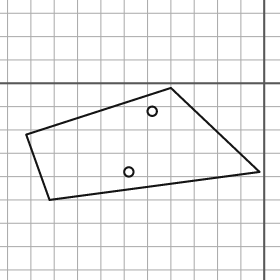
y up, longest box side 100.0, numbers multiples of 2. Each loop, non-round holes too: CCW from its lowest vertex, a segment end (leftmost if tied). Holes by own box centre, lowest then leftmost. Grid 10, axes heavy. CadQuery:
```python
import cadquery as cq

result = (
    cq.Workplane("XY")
    .moveTo(-92.0, -50.0)
    .lineTo(-2.0, -38.0)
    .lineTo(-40.0, -2.0)
    .lineTo(-102.0, -22.0)
    .close()
    .moveTo(-58.0, -38.0)
    .circle(2.0)
    .moveTo(-48.0, -12.0)
    .circle(2.0)
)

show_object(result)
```